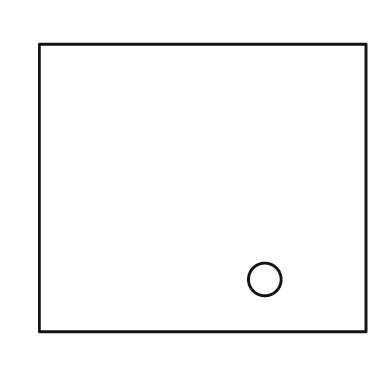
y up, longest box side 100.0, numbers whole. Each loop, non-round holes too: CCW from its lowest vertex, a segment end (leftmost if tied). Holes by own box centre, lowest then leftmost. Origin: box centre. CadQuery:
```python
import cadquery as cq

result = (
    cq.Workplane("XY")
    .moveTo(-50.0, -44.0)
    .lineTo(50.0, -44.0)
    .lineTo(50.0, 44.0)
    .lineTo(-50.0, 44.0)
    .close()
    .moveTo(19.0, -28.0)
    .circle(5.0)
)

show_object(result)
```